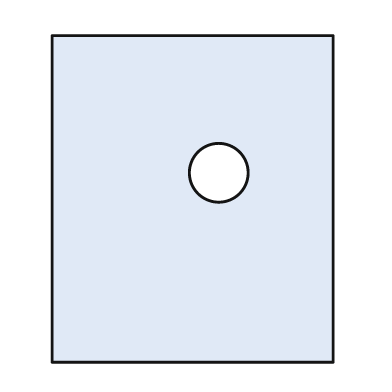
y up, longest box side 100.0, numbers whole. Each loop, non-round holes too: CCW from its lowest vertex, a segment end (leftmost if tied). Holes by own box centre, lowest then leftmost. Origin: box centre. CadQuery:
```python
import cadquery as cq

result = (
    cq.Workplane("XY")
    .moveTo(-43.0, -50.0)
    .lineTo(43.0, -50.0)
    .lineTo(43.0, 50.0)
    .lineTo(-43.0, 50.0)
    .close()
    .moveTo(8.0, 8.0)
    .circle(9.0)
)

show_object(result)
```